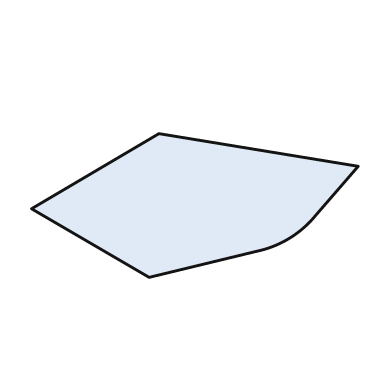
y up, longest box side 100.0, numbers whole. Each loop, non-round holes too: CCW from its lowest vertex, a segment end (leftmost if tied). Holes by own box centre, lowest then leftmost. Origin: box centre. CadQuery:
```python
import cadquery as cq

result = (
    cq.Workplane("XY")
    .moveTo(-14.0, -22.0)
    .lineTo(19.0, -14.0)
    .threePointArc((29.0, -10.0), (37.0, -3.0))
    .lineTo(50.0, 12.0)
    .lineTo(-11.0, 22.0)
    .lineTo(-50.0, -1.0)
    .close()
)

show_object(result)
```